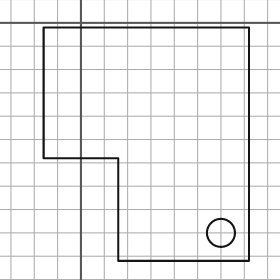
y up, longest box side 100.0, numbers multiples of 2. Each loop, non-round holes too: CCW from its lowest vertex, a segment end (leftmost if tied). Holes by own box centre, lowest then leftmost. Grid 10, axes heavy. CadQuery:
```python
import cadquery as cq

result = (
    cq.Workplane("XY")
    .moveTo(16.0, -102.0)
    .lineTo(72.0, -102.0)
    .lineTo(72.0, -2.0)
    .lineTo(-16.0, -2.0)
    .lineTo(-16.0, -58.0)
    .lineTo(16.0, -58.0)
    .close()
    .moveTo(60.0, -90.0)
    .circle(6.0)
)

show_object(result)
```